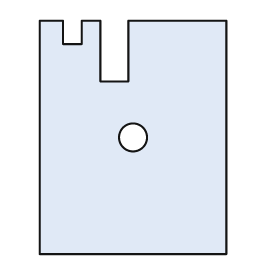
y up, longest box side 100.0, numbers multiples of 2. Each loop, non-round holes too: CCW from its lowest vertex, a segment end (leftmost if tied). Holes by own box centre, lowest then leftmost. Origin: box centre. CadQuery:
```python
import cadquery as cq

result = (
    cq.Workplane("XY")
    .moveTo(-40.0, -50.0)
    .lineTo(40.0, -50.0)
    .lineTo(40.0, 50.0)
    .lineTo(-2.0, 50.0)
    .lineTo(-2.0, 24.0)
    .lineTo(-14.0, 24.0)
    .lineTo(-14.0, 50.0)
    .lineTo(-22.0, 50.0)
    .lineTo(-22.0, 40.0)
    .lineTo(-30.0, 40.0)
    .lineTo(-30.0, 50.0)
    .lineTo(-40.0, 50.0)
    .close()
    .moveTo(0.0, 0.0)
    .circle(6.0)
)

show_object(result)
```